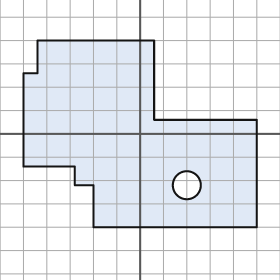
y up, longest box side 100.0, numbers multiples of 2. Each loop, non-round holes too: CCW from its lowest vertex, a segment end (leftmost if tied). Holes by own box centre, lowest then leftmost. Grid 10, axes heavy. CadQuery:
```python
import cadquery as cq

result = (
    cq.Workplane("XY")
    .moveTo(-20.0, -40.0)
    .lineTo(50.0, -40.0)
    .lineTo(50.0, 6.0)
    .lineTo(6.0, 6.0)
    .lineTo(6.0, 40.0)
    .lineTo(-44.0, 40.0)
    .lineTo(-44.0, 26.0)
    .lineTo(-50.0, 26.0)
    .lineTo(-50.0, -14.0)
    .lineTo(-28.0, -14.0)
    .lineTo(-28.0, -22.0)
    .lineTo(-20.0, -22.0)
    .close()
    .moveTo(20.0, -22.0)
    .circle(6.0)
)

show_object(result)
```